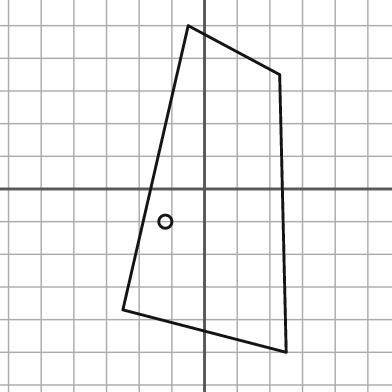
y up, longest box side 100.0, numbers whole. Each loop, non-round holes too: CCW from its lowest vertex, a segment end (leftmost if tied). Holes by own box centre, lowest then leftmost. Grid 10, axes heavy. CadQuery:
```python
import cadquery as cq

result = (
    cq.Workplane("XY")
    .moveTo(25.0, -50.0)
    .lineTo(23.0, 35.0)
    .lineTo(-5.0, 50.0)
    .lineTo(-25.0, -37.0)
    .close()
    .moveTo(-12.0, -10.0)
    .circle(2.0)
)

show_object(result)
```